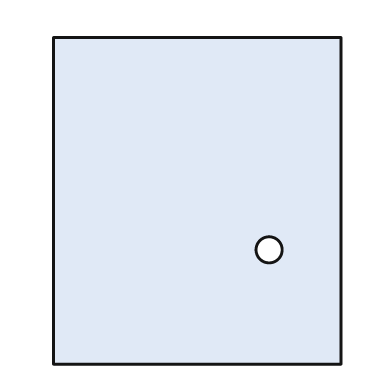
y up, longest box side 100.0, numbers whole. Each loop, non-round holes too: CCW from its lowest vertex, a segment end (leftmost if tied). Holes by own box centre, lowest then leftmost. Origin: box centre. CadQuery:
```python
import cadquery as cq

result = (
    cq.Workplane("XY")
    .moveTo(-44.0, -50.0)
    .lineTo(44.0, -50.0)
    .lineTo(44.0, 50.0)
    .lineTo(-44.0, 50.0)
    .close()
    .moveTo(22.0, -15.0)
    .circle(4.0)
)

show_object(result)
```